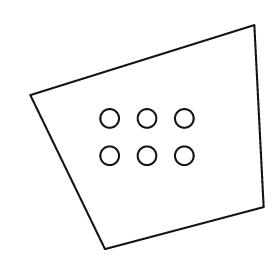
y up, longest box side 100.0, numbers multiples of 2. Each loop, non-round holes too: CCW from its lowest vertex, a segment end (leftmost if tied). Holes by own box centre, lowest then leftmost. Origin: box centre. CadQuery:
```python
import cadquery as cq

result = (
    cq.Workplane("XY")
    .moveTo(-18.0, -48.0)
    .lineTo(50.0, -30.0)
    .lineTo(46.0, 48.0)
    .lineTo(-50.0, 18.0)
    .close()
    .moveTo(-16.0, -8.0)
    .circle(4.0)
    .moveTo(0.0, -8.0)
    .circle(4.0)
    .moveTo(16.0, -8.0)
    .circle(4.0)
    .moveTo(-16.0, 8.0)
    .circle(4.0)
    .moveTo(0.0, 8.0)
    .circle(4.0)
    .moveTo(16.0, 8.0)
    .circle(4.0)
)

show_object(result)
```